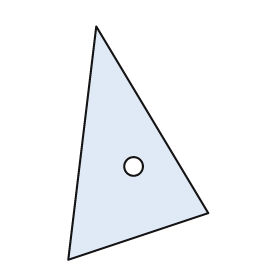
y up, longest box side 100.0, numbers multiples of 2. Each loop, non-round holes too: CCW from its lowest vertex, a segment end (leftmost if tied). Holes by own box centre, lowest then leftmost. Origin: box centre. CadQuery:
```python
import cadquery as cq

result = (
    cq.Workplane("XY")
    .moveTo(-30.0, -50.0)
    .lineTo(30.0, -30.0)
    .lineTo(-18.0, 50.0)
    .close()
    .moveTo(-2.0, -10.0)
    .circle(4.0)
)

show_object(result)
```